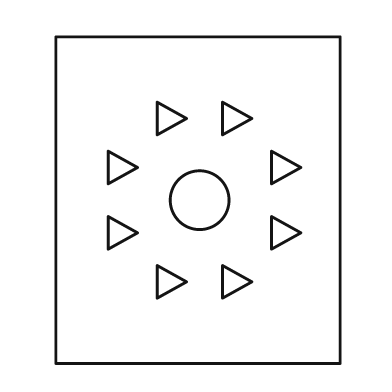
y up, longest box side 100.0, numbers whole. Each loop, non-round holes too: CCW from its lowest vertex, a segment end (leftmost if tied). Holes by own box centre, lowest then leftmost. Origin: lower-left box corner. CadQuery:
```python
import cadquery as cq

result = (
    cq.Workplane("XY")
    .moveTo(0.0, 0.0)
    .lineTo(87.0, 0.0)
    .lineTo(87.0, 100.0)
    .lineTo(0.0, 100.0)
    .close()
    .moveTo(31.0, 20.0)
    .lineTo(40.0, 25.0)
    .lineTo(31.0, 30.0)
    .close()
    .moveTo(51.0, 20.0)
    .lineTo(60.0, 25.0)
    .lineTo(51.0, 30.0)
    .close()
    .moveTo(16.0, 35.0)
    .lineTo(25.0, 40.0)
    .lineTo(16.0, 45.0)
    .close()
    .moveTo(66.0, 35.0)
    .lineTo(75.0, 40.0)
    .lineTo(66.0, 45.0)
    .close()
    .moveTo(44.0, 50.0)
    .circle(9.0)
    .moveTo(16.0, 55.0)
    .lineTo(25.0, 60.0)
    .lineTo(16.0, 65.0)
    .close()
    .moveTo(66.0, 55.0)
    .lineTo(75.0, 60.0)
    .lineTo(66.0, 65.0)
    .close()
    .moveTo(31.0, 70.0)
    .lineTo(40.0, 75.0)
    .lineTo(31.0, 80.0)
    .close()
    .moveTo(51.0, 70.0)
    .lineTo(60.0, 75.0)
    .lineTo(51.0, 80.0)
    .close()
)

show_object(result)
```